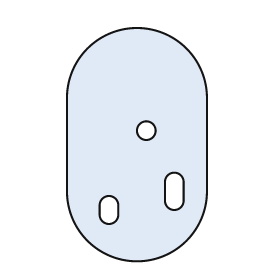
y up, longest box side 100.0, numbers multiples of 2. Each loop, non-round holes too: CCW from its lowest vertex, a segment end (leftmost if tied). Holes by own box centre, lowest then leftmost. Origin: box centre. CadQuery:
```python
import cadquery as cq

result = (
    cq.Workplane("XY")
    .moveTo(-30.0, -20.0)
    .threePointArc((0.0, -50.0), (30.0, -20.0))
    .lineTo(30.0, 20.0)
    .threePointArc((0.0, 50.0), (-30.0, 20.0))
    .close()
    .moveTo(-16.0, -30.0)
    .threePointArc((-12.0, -34.0), (-8.0, -30.0))
    .lineTo(-8.0, -26.0)
    .threePointArc((-12.0, -22.0), (-16.0, -26.0))
    .close()
    .moveTo(12.0, -24.0)
    .threePointArc((16.0, -28.0), (20.0, -24.0))
    .lineTo(20.0, -16.0)
    .threePointArc((16.0, -12.0), (12.0, -16.0))
    .close()
    .moveTo(4.0, 6.0)
    .circle(4.0)
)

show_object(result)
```